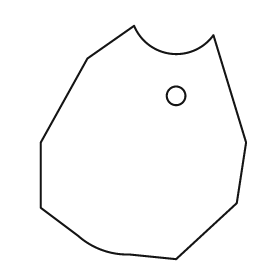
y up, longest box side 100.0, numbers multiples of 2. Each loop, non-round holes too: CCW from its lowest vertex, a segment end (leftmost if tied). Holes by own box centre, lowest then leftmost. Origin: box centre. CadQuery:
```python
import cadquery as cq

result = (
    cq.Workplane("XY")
    .moveTo(14.0, -50.0)
    .lineTo(40.0, -26.0)
    .lineTo(44.0, 0.0)
    .lineTo(30.0, 46.0)
    .threePointArc((12.0, 38.0), (-4.0, 50.0))
    .lineTo(-24.0, 36.0)
    .lineTo(-44.0, 0.0)
    .lineTo(-44.0, -28.0)
    .lineTo(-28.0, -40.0)
    .threePointArc((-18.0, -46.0), (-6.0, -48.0))
    .close()
    .moveTo(14.0, 20.0)
    .circle(4.0)
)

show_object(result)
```